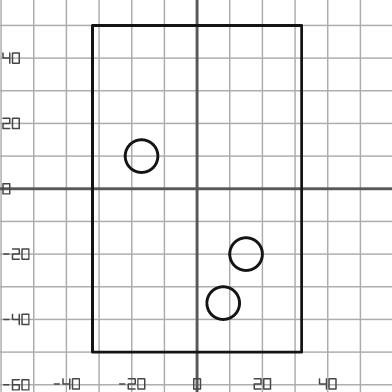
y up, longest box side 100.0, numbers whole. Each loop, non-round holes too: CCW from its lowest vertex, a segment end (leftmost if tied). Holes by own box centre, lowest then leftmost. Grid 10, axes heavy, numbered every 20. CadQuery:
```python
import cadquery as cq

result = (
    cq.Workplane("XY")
    .moveTo(-32.0, -50.0)
    .lineTo(32.0, -50.0)
    .lineTo(32.0, 50.0)
    .lineTo(-32.0, 50.0)
    .close()
    .moveTo(8.0, -35.0)
    .circle(5.0)
    .moveTo(15.0, -20.0)
    .circle(5.0)
    .moveTo(-17.0, 10.0)
    .circle(5.0)
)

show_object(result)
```